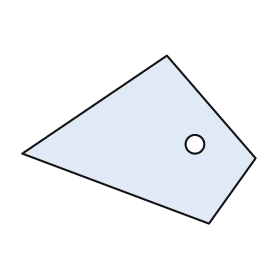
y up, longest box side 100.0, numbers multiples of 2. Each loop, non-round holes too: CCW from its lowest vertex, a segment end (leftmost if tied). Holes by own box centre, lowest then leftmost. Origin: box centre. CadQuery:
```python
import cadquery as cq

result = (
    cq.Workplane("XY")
    .moveTo(30.0, -36.0)
    .lineTo(50.0, -8.0)
    .lineTo(12.0, 36.0)
    .lineTo(-50.0, -6.0)
    .close()
    .moveTo(24.0, -2.0)
    .circle(4.0)
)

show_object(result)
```